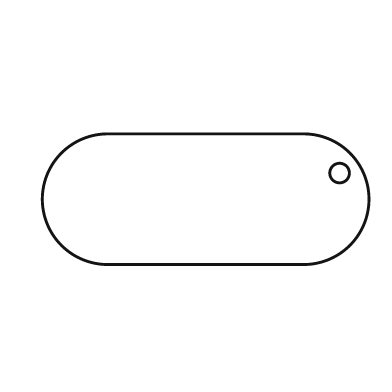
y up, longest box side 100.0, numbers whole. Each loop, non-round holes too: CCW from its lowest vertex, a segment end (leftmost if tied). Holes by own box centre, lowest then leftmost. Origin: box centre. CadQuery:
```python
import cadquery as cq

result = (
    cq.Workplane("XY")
    .moveTo(-30.0, -20.0)
    .lineTo(30.0, -20.0)
    .threePointArc((50.0, 0.0), (30.0, 20.0))
    .lineTo(-30.0, 20.0)
    .threePointArc((-50.0, 0.0), (-30.0, -20.0))
    .close()
    .moveTo(41.0, 8.0)
    .circle(3.0)
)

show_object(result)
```